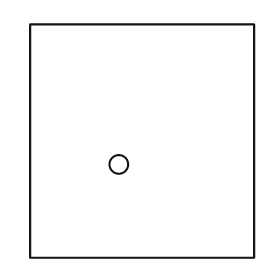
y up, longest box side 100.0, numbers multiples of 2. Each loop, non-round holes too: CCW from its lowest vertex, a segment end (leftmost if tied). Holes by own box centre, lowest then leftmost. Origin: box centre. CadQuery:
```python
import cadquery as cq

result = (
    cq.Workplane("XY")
    .moveTo(-48.0, -50.0)
    .lineTo(48.0, -50.0)
    .lineTo(48.0, 50.0)
    .lineTo(-48.0, 50.0)
    .close()
    .moveTo(-10.0, -10.0)
    .circle(4.0)
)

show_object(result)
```